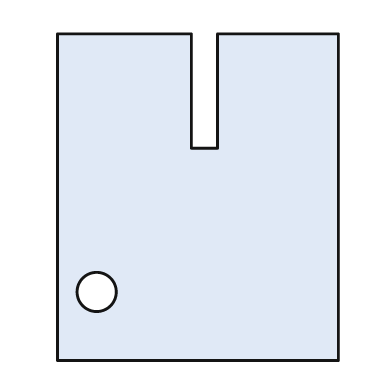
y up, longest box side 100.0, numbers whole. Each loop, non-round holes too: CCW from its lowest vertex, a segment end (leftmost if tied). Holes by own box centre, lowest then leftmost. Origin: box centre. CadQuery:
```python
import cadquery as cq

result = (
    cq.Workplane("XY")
    .moveTo(-43.0, -50.0)
    .lineTo(43.0, -50.0)
    .lineTo(43.0, 50.0)
    .lineTo(6.0, 50.0)
    .lineTo(6.0, 15.0)
    .lineTo(-2.0, 15.0)
    .lineTo(-2.0, 50.0)
    .lineTo(-43.0, 50.0)
    .close()
    .moveTo(-31.0, -29.0)
    .circle(6.0)
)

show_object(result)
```